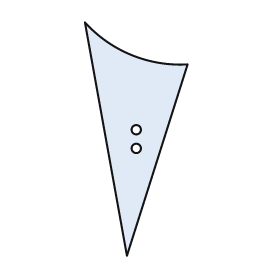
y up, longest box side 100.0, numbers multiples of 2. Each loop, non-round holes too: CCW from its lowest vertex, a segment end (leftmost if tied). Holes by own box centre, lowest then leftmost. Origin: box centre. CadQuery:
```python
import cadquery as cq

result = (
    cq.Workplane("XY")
    .moveTo(-4.0, -50.0)
    .lineTo(22.0, 32.0)
    .threePointArc((-2.0, 36.0), (-22.0, 50.0))
    .close()
    .moveTo(0.0, -4.0)
    .circle(2.0)
    .moveTo(0.0, 4.0)
    .circle(2.0)
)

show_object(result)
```